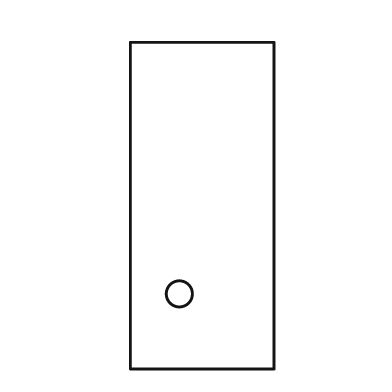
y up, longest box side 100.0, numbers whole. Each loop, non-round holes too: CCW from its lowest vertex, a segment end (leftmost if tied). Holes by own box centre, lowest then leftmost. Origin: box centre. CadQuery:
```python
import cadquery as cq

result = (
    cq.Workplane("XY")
    .moveTo(-22.0, -50.0)
    .lineTo(22.0, -50.0)
    .lineTo(22.0, 50.0)
    .lineTo(-22.0, 50.0)
    .close()
    .moveTo(-7.0, -27.0)
    .circle(4.0)
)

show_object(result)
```